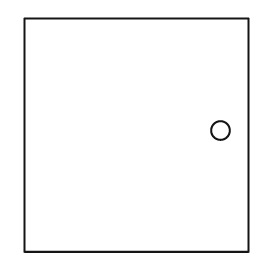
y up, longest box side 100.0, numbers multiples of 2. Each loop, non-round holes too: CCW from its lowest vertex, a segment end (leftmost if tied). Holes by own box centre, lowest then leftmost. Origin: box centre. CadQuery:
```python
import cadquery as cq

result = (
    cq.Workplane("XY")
    .moveTo(-48.0, -50.0)
    .lineTo(48.0, -50.0)
    .lineTo(48.0, 50.0)
    .lineTo(-48.0, 50.0)
    .close()
    .moveTo(36.0, 2.0)
    .circle(4.0)
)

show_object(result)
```